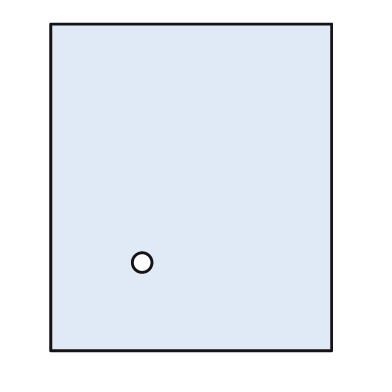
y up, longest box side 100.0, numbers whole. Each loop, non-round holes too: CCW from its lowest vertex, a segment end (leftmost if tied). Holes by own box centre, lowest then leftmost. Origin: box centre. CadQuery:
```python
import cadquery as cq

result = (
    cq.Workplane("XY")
    .moveTo(-43.0, -50.0)
    .lineTo(43.0, -50.0)
    .lineTo(43.0, 50.0)
    .lineTo(-43.0, 50.0)
    .close()
    .moveTo(-15.0, -23.0)
    .circle(3.0)
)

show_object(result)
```